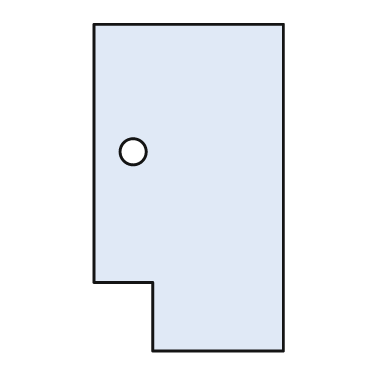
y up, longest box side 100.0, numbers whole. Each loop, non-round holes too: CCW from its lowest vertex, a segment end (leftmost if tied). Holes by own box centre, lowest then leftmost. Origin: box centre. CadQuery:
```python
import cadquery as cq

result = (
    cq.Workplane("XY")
    .moveTo(-11.0, -50.0)
    .lineTo(29.0, -50.0)
    .lineTo(29.0, 50.0)
    .lineTo(-29.0, 50.0)
    .lineTo(-29.0, -29.0)
    .lineTo(-11.0, -29.0)
    .close()
    .moveTo(-17.0, 11.0)
    .circle(4.0)
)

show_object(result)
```